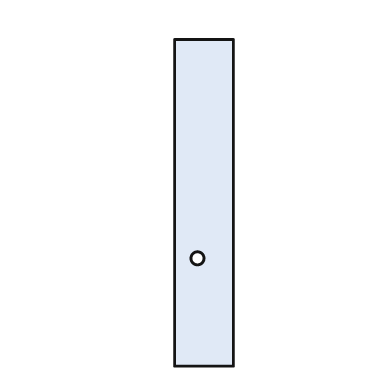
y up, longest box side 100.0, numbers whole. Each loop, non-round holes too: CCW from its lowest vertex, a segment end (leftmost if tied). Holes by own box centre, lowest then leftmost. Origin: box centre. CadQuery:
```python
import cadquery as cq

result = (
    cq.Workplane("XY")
    .moveTo(-9.0, -50.0)
    .lineTo(9.0, -50.0)
    .lineTo(9.0, 50.0)
    .lineTo(-9.0, 50.0)
    .close()
    .moveTo(-2.0, -17.0)
    .circle(2.0)
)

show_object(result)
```